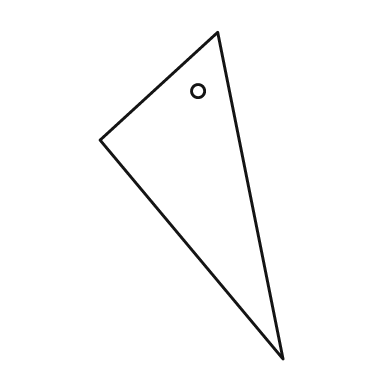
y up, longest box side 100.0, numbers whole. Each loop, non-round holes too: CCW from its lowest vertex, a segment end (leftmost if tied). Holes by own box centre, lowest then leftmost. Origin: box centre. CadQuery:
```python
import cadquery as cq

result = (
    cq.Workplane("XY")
    .moveTo(28.0, -50.0)
    .lineTo(8.0, 50.0)
    .lineTo(-28.0, 17.0)
    .close()
    .moveTo(2.0, 32.0)
    .circle(2.0)
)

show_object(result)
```